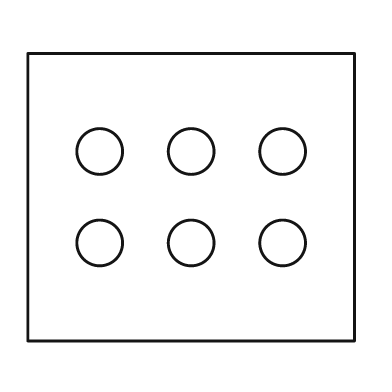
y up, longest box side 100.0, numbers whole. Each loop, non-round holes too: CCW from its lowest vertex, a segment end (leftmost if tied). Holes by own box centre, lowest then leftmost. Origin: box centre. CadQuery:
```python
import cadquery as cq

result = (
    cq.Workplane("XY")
    .moveTo(-50.0, -44.0)
    .lineTo(50.0, -44.0)
    .lineTo(50.0, 44.0)
    .lineTo(-50.0, 44.0)
    .close()
    .moveTo(-28.0, -14.0)
    .circle(7.0)
    .moveTo(0.0, -14.0)
    .circle(7.0)
    .moveTo(28.0, -14.0)
    .circle(7.0)
    .moveTo(-28.0, 14.0)
    .circle(7.0)
    .moveTo(0.0, 14.0)
    .circle(7.0)
    .moveTo(28.0, 14.0)
    .circle(7.0)
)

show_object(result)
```